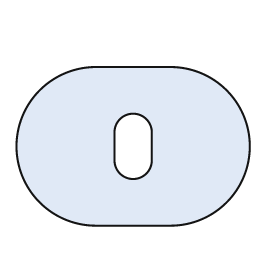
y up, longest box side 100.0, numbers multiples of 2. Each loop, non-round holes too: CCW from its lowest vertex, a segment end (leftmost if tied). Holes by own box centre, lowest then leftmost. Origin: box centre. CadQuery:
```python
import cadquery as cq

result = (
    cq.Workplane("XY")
    .moveTo(-16.0, -34.0)
    .lineTo(16.0, -34.0)
    .threePointArc((50.0, 0.0), (16.0, 34.0))
    .lineTo(-16.0, 34.0)
    .threePointArc((-50.0, 0.0), (-16.0, -34.0))
    .close()
    .moveTo(-8.0, -6.0)
    .threePointArc((0.0, -14.0), (8.0, -6.0))
    .lineTo(8.0, 6.0)
    .threePointArc((0.0, 14.0), (-8.0, 6.0))
    .close()
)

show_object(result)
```